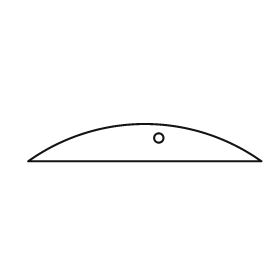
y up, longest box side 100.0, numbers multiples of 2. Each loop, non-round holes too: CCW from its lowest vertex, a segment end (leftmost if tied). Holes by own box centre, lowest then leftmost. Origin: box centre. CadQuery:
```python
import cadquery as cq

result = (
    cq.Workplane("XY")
    .moveTo(-50.0, -8.0)
    .lineTo(50.0, -8.0)
    .threePointArc((0.0, 8.0), (-50.0, -8.0))
    .close()
    .moveTo(6.0, 2.0)
    .circle(2.0)
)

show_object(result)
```